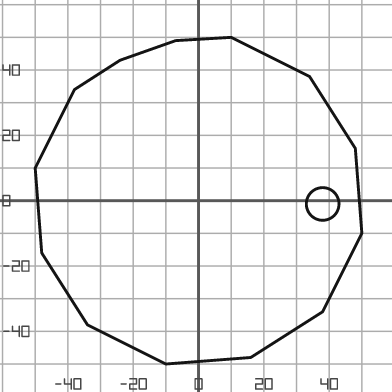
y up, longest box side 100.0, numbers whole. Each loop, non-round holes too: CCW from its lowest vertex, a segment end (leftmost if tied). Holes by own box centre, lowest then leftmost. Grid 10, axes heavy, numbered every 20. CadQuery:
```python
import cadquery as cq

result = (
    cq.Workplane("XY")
    .moveTo(-10.0, -50.0)
    .lineTo(16.0, -48.0)
    .lineTo(38.0, -34.0)
    .lineTo(50.0, -10.0)
    .lineTo(48.0, 16.0)
    .lineTo(34.0, 38.0)
    .lineTo(10.0, 50.0)
    .lineTo(-7.0, 49.0)
    .lineTo(-24.0, 43.0)
    .lineTo(-38.0, 34.0)
    .lineTo(-50.0, 10.0)
    .lineTo(-48.0, -16.0)
    .lineTo(-34.0, -38.0)
    .close()
    .moveTo(38.0, -1.0)
    .circle(5.0)
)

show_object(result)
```